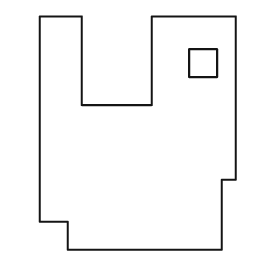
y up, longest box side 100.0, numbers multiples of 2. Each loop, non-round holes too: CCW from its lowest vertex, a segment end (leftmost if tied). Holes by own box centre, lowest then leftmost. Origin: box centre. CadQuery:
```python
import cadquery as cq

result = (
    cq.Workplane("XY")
    .moveTo(-30.0, -50.0)
    .lineTo(36.0, -50.0)
    .lineTo(36.0, -20.0)
    .lineTo(42.0, -20.0)
    .lineTo(42.0, 50.0)
    .lineTo(6.0, 50.0)
    .lineTo(6.0, 12.0)
    .lineTo(-24.0, 12.0)
    .lineTo(-24.0, 50.0)
    .lineTo(-42.0, 50.0)
    .lineTo(-42.0, -38.0)
    .lineTo(-30.0, -38.0)
    .close()
    .moveTo(22.0, 24.0)
    .lineTo(34.0, 24.0)
    .lineTo(34.0, 36.0)
    .lineTo(22.0, 36.0)
    .close()
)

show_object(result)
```